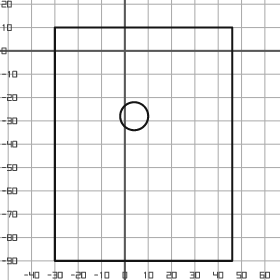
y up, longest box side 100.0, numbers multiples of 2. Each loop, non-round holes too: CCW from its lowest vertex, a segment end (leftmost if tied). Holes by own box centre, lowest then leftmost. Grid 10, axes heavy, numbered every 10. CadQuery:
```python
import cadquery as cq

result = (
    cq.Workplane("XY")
    .moveTo(-30.0, -90.0)
    .lineTo(46.0, -90.0)
    .lineTo(46.0, 10.0)
    .lineTo(-30.0, 10.0)
    .close()
    .moveTo(4.0, -28.0)
    .circle(6.0)
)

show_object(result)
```